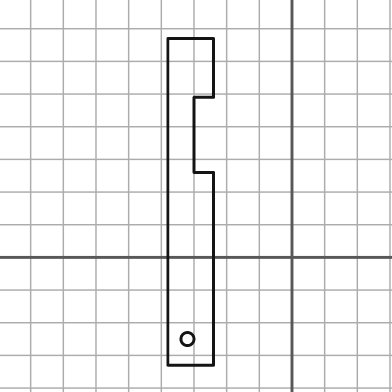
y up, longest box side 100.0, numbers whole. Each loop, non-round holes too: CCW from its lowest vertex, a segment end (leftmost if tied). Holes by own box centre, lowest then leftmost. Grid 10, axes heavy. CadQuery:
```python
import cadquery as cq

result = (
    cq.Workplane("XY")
    .moveTo(-38.0, -33.0)
    .lineTo(-24.0, -33.0)
    .lineTo(-24.0, 26.0)
    .lineTo(-30.0, 26.0)
    .lineTo(-30.0, 49.0)
    .lineTo(-24.0, 49.0)
    .lineTo(-24.0, 67.0)
    .lineTo(-38.0, 67.0)
    .close()
    .moveTo(-32.0, -25.0)
    .circle(2.0)
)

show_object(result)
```